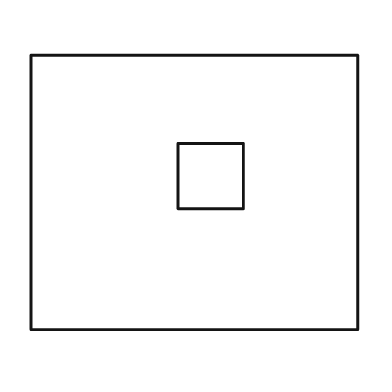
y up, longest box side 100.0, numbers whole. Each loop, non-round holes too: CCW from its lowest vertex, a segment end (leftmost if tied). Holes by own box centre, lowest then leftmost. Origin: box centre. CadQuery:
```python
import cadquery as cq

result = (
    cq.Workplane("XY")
    .moveTo(-50.0, -42.0)
    .lineTo(50.0, -42.0)
    .lineTo(50.0, 42.0)
    .lineTo(-50.0, 42.0)
    .close()
    .moveTo(-5.0, -5.0)
    .lineTo(15.0, -5.0)
    .lineTo(15.0, 15.0)
    .lineTo(-5.0, 15.0)
    .close()
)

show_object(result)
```